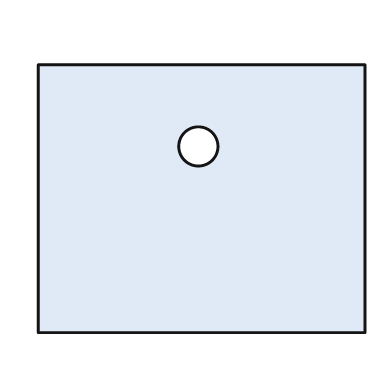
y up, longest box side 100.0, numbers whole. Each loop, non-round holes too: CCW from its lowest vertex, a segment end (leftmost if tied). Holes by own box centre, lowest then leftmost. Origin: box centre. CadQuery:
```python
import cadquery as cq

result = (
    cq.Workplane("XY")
    .moveTo(-50.0, -41.0)
    .lineTo(50.0, -41.0)
    .lineTo(50.0, 41.0)
    .lineTo(-50.0, 41.0)
    .close()
    .moveTo(-1.0, 16.0)
    .circle(6.0)
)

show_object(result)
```